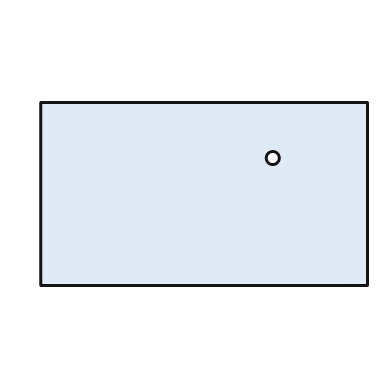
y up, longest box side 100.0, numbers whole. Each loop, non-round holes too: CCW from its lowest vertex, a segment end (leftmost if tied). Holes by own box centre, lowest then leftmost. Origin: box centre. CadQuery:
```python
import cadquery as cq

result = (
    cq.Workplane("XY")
    .moveTo(-50.0, -28.0)
    .lineTo(50.0, -28.0)
    .lineTo(50.0, 28.0)
    .lineTo(-50.0, 28.0)
    .close()
    .moveTo(21.0, 11.0)
    .circle(2.0)
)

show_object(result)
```